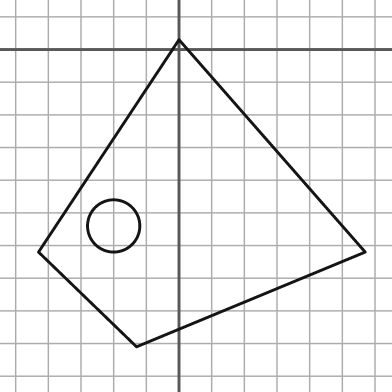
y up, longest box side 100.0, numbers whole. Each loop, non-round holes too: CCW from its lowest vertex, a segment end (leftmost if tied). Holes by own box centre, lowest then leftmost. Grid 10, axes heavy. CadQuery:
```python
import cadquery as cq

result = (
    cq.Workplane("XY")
    .moveTo(-13.0, -91.0)
    .lineTo(57.0, -62.0)
    .lineTo(0.0, 3.0)
    .lineTo(-43.0, -62.0)
    .close()
    .moveTo(-20.0, -54.0)
    .circle(8.0)
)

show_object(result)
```